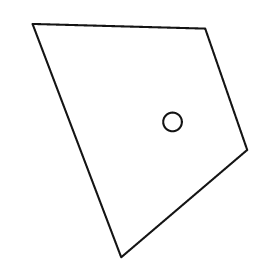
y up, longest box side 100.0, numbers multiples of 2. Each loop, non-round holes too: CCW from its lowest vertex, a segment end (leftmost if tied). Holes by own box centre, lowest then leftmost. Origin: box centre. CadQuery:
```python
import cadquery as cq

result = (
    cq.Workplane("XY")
    .moveTo(-8.0, -50.0)
    .lineTo(46.0, -4.0)
    .lineTo(28.0, 48.0)
    .lineTo(-46.0, 50.0)
    .close()
    .moveTo(14.0, 8.0)
    .circle(4.0)
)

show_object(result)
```